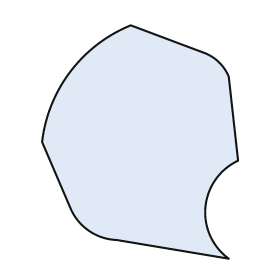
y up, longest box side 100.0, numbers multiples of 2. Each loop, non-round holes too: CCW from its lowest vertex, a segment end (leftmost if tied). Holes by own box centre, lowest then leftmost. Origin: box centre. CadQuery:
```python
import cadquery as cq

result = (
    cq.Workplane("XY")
    .moveTo(38.0, -50.0)
    .threePointArc((28.0, -28.0), (42.0, -8.0))
    .lineTo(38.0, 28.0)
    .threePointArc((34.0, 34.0), (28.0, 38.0))
    .lineTo(-4.0, 50.0)
    .threePointArc((-30.0, 30.0), (-42.0, 0.0))
    .lineTo(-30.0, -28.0)
    .threePointArc((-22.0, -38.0), (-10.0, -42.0))
    .close()
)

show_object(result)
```